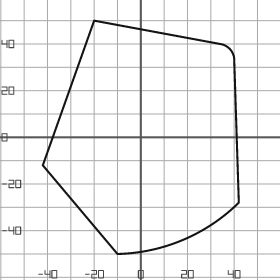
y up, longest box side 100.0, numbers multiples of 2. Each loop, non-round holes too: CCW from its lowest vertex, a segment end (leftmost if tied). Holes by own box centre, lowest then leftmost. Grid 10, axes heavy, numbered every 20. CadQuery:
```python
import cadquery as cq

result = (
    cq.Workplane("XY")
    .moveTo(-10.0, -50.0)
    .threePointArc((18.0, -44.0), (42.0, -28.0))
    .lineTo(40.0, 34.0)
    .threePointArc((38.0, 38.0), (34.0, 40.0))
    .lineTo(-20.0, 50.0)
    .lineTo(-42.0, -12.0)
    .close()
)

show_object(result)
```